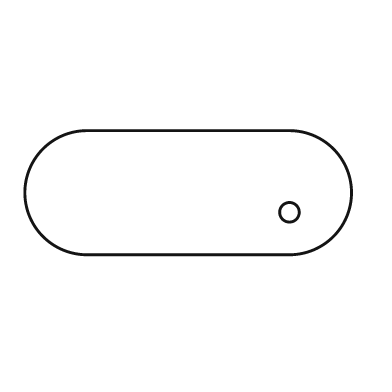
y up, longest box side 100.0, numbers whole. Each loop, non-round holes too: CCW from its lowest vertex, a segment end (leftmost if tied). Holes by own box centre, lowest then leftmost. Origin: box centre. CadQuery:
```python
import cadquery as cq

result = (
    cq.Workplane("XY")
    .moveTo(-31.0, -19.0)
    .lineTo(31.0, -19.0)
    .threePointArc((50.0, 0.0), (31.0, 19.0))
    .lineTo(-31.0, 19.0)
    .threePointArc((-50.0, 0.0), (-31.0, -19.0))
    .close()
    .moveTo(31.0, -6.0)
    .circle(3.0)
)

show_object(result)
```